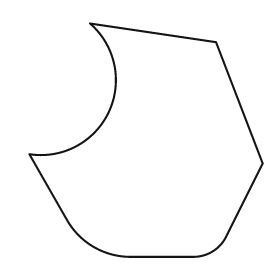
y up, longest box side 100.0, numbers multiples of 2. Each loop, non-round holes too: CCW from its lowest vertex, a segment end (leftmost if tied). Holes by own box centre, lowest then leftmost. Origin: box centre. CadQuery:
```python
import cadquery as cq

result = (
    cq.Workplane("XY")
    .moveTo(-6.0, -50.0)
    .lineTo(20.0, -50.0)
    .threePointArc((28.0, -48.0), (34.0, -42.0))
    .lineTo(50.0, -10.0)
    .lineTo(30.0, 42.0)
    .lineTo(-24.0, 50.0)
    .threePointArc((-16.0, 12.0), (-50.0, -6.0))
    .lineTo(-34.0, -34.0)
    .threePointArc((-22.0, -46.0), (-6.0, -50.0))
    .close()
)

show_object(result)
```